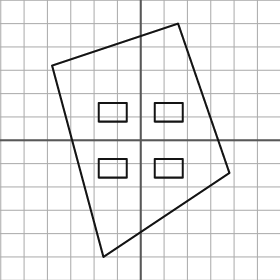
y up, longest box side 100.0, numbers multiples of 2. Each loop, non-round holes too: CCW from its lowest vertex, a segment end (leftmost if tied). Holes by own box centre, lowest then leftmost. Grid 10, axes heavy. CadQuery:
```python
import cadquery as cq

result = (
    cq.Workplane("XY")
    .moveTo(-16.0, -50.0)
    .lineTo(38.0, -14.0)
    .lineTo(16.0, 50.0)
    .lineTo(-38.0, 32.0)
    .close()
    .moveTo(-18.0, -16.0)
    .lineTo(-6.0, -16.0)
    .lineTo(-6.0, -8.0)
    .lineTo(-18.0, -8.0)
    .close()
    .moveTo(6.0, -16.0)
    .lineTo(18.0, -16.0)
    .lineTo(18.0, -8.0)
    .lineTo(6.0, -8.0)
    .close()
    .moveTo(-18.0, 8.0)
    .lineTo(-6.0, 8.0)
    .lineTo(-6.0, 16.0)
    .lineTo(-18.0, 16.0)
    .close()
    .moveTo(6.0, 8.0)
    .lineTo(18.0, 8.0)
    .lineTo(18.0, 16.0)
    .lineTo(6.0, 16.0)
    .close()
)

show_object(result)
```